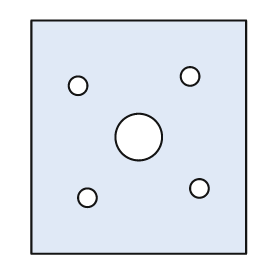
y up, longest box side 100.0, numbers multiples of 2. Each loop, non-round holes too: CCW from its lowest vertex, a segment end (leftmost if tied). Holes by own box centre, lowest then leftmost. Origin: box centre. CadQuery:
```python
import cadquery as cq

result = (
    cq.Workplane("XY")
    .moveTo(-46.0, -50.0)
    .lineTo(46.0, -50.0)
    .lineTo(46.0, 50.0)
    .lineTo(-46.0, 50.0)
    .close()
    .moveTo(-22.0, -26.0)
    .circle(4.0)
    .moveTo(26.0, -22.0)
    .circle(4.0)
    .moveTo(0.0, 0.0)
    .circle(10.0)
    .moveTo(-26.0, 22.0)
    .circle(4.0)
    .moveTo(22.0, 26.0)
    .circle(4.0)
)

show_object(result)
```